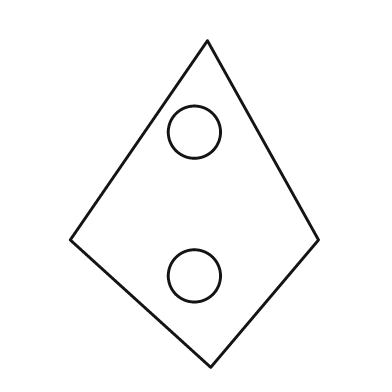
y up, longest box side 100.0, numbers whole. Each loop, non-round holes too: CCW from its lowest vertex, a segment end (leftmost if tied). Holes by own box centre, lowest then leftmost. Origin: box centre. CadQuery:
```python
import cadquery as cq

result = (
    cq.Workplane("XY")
    .moveTo(5.0, -50.0)
    .lineTo(38.0, -11.0)
    .lineTo(4.0, 50.0)
    .lineTo(-38.0, -11.0)
    .close()
    .moveTo(0.0, -22.0)
    .circle(8.0)
    .moveTo(0.0, 22.0)
    .circle(8.0)
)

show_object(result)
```